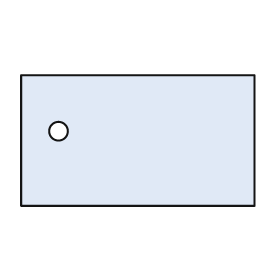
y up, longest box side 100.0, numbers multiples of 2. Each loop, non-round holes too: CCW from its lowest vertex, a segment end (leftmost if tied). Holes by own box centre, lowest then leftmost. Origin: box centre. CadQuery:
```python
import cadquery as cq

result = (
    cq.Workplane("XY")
    .moveTo(-50.0, -28.0)
    .lineTo(50.0, -28.0)
    .lineTo(50.0, 28.0)
    .lineTo(-50.0, 28.0)
    .close()
    .moveTo(-34.0, 4.0)
    .circle(4.0)
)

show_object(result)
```